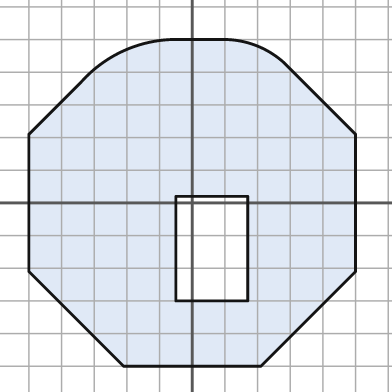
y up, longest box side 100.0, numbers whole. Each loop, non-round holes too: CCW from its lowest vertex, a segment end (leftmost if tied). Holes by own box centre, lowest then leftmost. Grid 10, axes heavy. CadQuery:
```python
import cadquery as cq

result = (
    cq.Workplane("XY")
    .moveTo(-21.0, -50.0)
    .lineTo(21.0, -50.0)
    .lineTo(50.0, -21.0)
    .lineTo(50.0, 21.0)
    .lineTo(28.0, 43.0)
    .threePointArc((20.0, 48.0), (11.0, 50.0))
    .lineTo(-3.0, 50.0)
    .threePointArc((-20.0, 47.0), (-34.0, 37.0))
    .lineTo(-50.0, 21.0)
    .lineTo(-50.0, -21.0)
    .close()
    .moveTo(-5.0, -30.0)
    .lineTo(17.0, -30.0)
    .lineTo(17.0, 2.0)
    .lineTo(-5.0, 2.0)
    .close()
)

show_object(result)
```